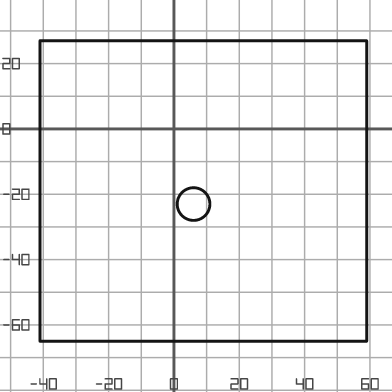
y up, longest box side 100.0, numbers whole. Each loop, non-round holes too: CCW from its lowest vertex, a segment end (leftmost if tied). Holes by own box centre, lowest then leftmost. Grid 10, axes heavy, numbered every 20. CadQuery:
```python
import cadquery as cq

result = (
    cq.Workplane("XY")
    .moveTo(-41.0, -65.0)
    .lineTo(59.0, -65.0)
    .lineTo(59.0, 27.0)
    .lineTo(-41.0, 27.0)
    .close()
    .moveTo(6.0, -23.0)
    .circle(5.0)
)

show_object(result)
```